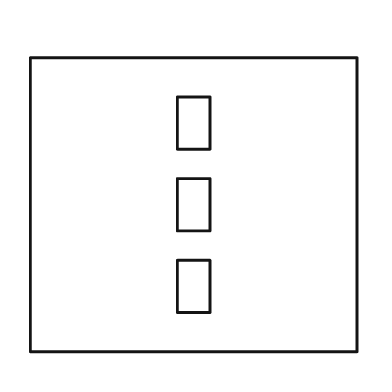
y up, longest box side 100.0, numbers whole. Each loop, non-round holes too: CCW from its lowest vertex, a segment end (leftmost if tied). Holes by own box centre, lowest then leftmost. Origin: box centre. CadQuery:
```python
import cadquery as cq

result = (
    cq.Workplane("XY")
    .moveTo(-50.0, -45.0)
    .lineTo(50.0, -45.0)
    .lineTo(50.0, 45.0)
    .lineTo(-50.0, 45.0)
    .close()
    .moveTo(-5.0, -33.0)
    .lineTo(5.0, -33.0)
    .lineTo(5.0, -17.0)
    .lineTo(-5.0, -17.0)
    .close()
    .moveTo(-5.0, -8.0)
    .lineTo(5.0, -8.0)
    .lineTo(5.0, 8.0)
    .lineTo(-5.0, 8.0)
    .close()
    .moveTo(-5.0, 17.0)
    .lineTo(5.0, 17.0)
    .lineTo(5.0, 33.0)
    .lineTo(-5.0, 33.0)
    .close()
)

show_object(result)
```